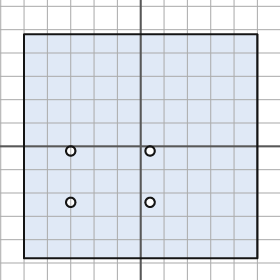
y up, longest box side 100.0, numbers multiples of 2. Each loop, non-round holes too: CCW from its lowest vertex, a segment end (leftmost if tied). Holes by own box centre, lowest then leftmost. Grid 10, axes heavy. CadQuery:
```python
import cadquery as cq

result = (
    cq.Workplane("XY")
    .moveTo(-50.0, -48.0)
    .lineTo(50.0, -48.0)
    .lineTo(50.0, 48.0)
    .lineTo(-50.0, 48.0)
    .close()
    .moveTo(-30.0, -24.0)
    .circle(2.0)
    .moveTo(4.0, -24.0)
    .circle(2.0)
    .moveTo(-30.0, -2.0)
    .circle(2.0)
    .moveTo(4.0, -2.0)
    .circle(2.0)
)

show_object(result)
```